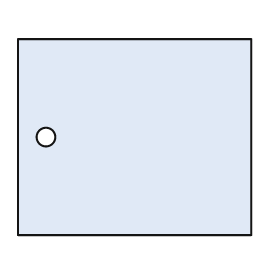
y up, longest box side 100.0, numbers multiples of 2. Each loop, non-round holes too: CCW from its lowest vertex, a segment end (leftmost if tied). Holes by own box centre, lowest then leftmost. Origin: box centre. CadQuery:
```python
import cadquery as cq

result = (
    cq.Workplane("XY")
    .moveTo(-50.0, -42.0)
    .lineTo(50.0, -42.0)
    .lineTo(50.0, 42.0)
    .lineTo(-50.0, 42.0)
    .close()
    .moveTo(-38.0, 0.0)
    .circle(4.0)
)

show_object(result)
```